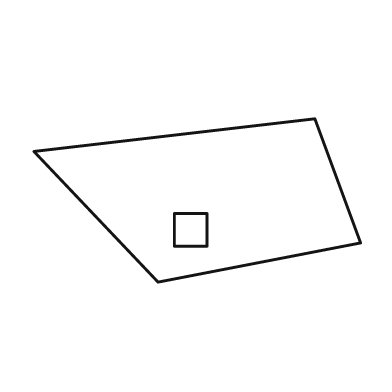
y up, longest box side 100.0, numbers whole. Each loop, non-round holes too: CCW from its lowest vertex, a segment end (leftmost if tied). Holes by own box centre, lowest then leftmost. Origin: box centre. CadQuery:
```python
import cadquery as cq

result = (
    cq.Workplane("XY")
    .moveTo(-12.0, -25.0)
    .lineTo(50.0, -13.0)
    .lineTo(36.0, 25.0)
    .lineTo(-50.0, 15.0)
    .close()
    .moveTo(-7.0, -14.0)
    .lineTo(3.0, -14.0)
    .lineTo(3.0, -4.0)
    .lineTo(-7.0, -4.0)
    .close()
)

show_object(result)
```